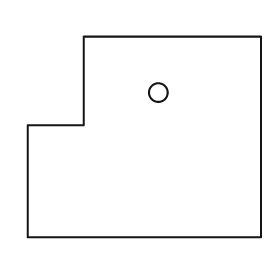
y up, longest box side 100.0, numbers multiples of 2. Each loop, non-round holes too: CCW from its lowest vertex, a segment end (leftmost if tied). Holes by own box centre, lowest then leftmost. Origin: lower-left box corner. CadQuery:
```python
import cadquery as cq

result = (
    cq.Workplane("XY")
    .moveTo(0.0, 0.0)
    .lineTo(100.0, 0.0)
    .lineTo(100.0, 86.0)
    .lineTo(24.0, 86.0)
    .lineTo(24.0, 48.0)
    .lineTo(0.0, 48.0)
    .close()
    .moveTo(56.0, 62.0)
    .circle(4.0)
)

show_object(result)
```